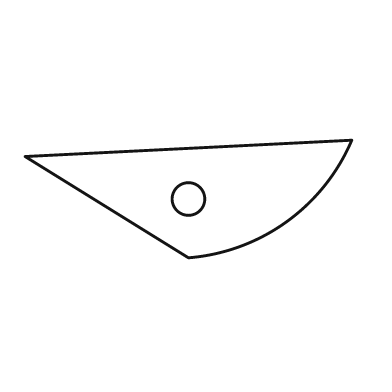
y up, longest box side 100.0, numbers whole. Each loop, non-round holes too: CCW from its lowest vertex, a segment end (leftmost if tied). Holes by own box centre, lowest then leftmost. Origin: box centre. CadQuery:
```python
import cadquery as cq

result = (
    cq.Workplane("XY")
    .moveTo(0.0, -18.0)
    .threePointArc((30.0, -7.0), (50.0, 18.0))
    .lineTo(-50.0, 13.0)
    .close()
    .moveTo(0.0, 0.0)
    .circle(5.0)
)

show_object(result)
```